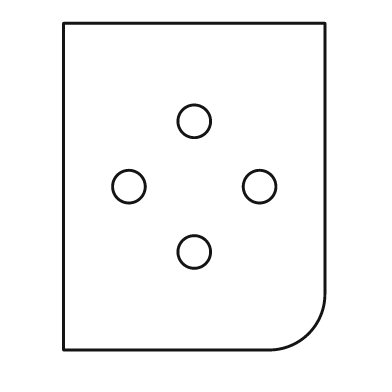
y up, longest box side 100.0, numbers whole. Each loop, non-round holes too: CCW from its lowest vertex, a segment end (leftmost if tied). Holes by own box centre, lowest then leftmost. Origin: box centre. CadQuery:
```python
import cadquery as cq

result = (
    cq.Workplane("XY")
    .moveTo(-40.0, -50.0)
    .lineTo(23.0, -50.0)
    .threePointArc((35.0, -45.0), (40.0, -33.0))
    .lineTo(40.0, 50.0)
    .lineTo(-40.0, 50.0)
    .close()
    .moveTo(0.0, -20.0)
    .circle(5.0)
    .moveTo(-20.0, 0.0)
    .circle(5.0)
    .moveTo(20.0, 0.0)
    .circle(5.0)
    .moveTo(0.0, 20.0)
    .circle(5.0)
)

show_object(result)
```